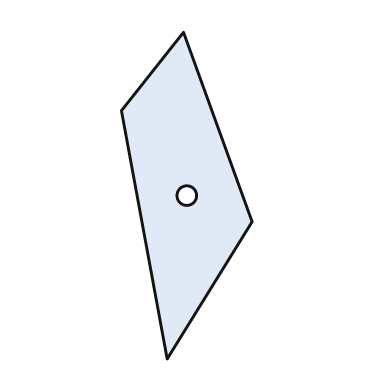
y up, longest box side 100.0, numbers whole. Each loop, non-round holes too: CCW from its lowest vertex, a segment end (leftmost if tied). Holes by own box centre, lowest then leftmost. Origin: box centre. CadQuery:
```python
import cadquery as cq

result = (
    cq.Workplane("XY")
    .moveTo(-6.0, -50.0)
    .lineTo(20.0, -8.0)
    .lineTo(-1.0, 50.0)
    .lineTo(-20.0, 26.0)
    .close()
    .moveTo(0.0, 0.0)
    .circle(3.0)
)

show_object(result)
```